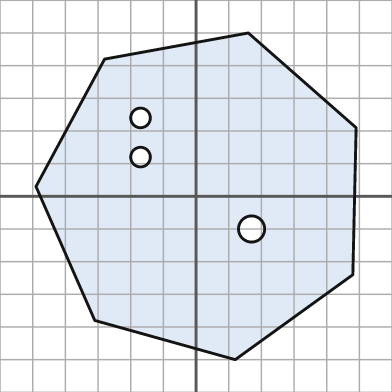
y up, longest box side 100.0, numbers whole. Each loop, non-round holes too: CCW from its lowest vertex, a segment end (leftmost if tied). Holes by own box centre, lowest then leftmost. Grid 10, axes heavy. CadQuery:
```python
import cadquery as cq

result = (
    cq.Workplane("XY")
    .moveTo(12.0, -50.0)
    .lineTo(48.0, -24.0)
    .lineTo(49.0, 21.0)
    .lineTo(16.0, 50.0)
    .lineTo(-28.0, 42.0)
    .lineTo(-49.0, 3.0)
    .lineTo(-31.0, -38.0)
    .close()
    .moveTo(17.0, -10.0)
    .circle(4.0)
    .moveTo(-17.0, 12.0)
    .circle(3.0)
    .moveTo(-17.0, 24.0)
    .circle(3.0)
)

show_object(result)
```